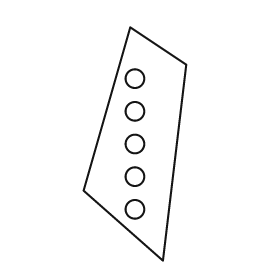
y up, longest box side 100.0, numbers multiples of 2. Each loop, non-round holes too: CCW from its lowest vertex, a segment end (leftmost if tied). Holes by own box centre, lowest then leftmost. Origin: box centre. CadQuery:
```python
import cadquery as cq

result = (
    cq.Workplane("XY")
    .moveTo(12.0, -50.0)
    .lineTo(22.0, 34.0)
    .lineTo(-2.0, 50.0)
    .lineTo(-22.0, -20.0)
    .close()
    .moveTo(0.0, -28.0)
    .circle(4.0)
    .moveTo(0.0, -14.0)
    .circle(4.0)
    .moveTo(0.0, 0.0)
    .circle(4.0)
    .moveTo(0.0, 14.0)
    .circle(4.0)
    .moveTo(0.0, 28.0)
    .circle(4.0)
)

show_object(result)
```